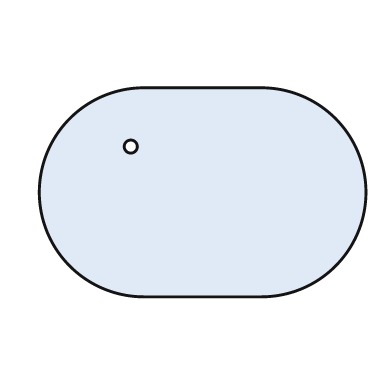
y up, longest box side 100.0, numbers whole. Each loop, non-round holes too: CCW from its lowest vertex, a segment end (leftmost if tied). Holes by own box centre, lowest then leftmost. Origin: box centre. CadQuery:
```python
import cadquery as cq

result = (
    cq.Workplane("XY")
    .moveTo(-18.0, -32.0)
    .lineTo(18.0, -32.0)
    .threePointArc((50.0, 0.0), (18.0, 32.0))
    .lineTo(-18.0, 32.0)
    .threePointArc((-50.0, 0.0), (-18.0, -32.0))
    .close()
    .moveTo(-22.0, 14.0)
    .circle(2.0)
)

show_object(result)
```